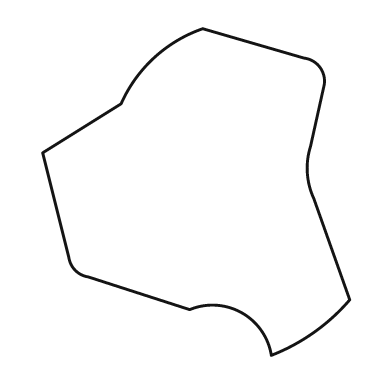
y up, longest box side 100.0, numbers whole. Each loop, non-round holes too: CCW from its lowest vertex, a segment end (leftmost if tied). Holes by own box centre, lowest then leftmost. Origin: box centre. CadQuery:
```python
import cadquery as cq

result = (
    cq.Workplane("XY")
    .moveTo(23.0, -50.0)
    .threePointArc((36.0, -43.0), (47.0, -33.0))
    .lineTo(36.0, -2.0)
    .threePointArc((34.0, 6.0), (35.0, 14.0))
    .lineTo(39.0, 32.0)
    .threePointArc((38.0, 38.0), (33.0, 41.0))
    .lineTo(2.0, 50.0)
    .threePointArc((-13.0, 41.0), (-23.0, 27.0))
    .lineTo(-47.0, 12.0)
    .lineTo(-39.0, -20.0)
    .threePointArc((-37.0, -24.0), (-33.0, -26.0))
    .lineTo(-2.0, -36.0)
    .threePointArc((14.0, -37.0), (23.0, -50.0))
    .close()
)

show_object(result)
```